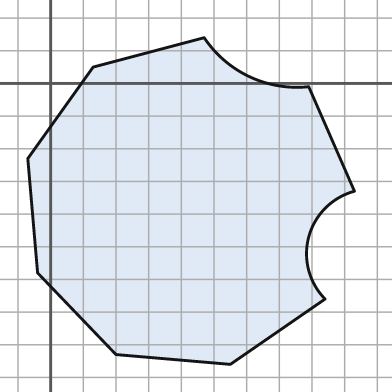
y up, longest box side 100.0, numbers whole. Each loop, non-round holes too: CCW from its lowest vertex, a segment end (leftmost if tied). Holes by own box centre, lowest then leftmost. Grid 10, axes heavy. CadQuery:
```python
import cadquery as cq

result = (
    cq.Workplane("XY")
    .moveTo(55.0, -86.0)
    .lineTo(84.0, -66.0)
    .threePointArc((79.0, -47.0), (93.0, -33.0))
    .lineTo(79.0, -1.0)
    .threePointArc((61.0, 2.0), (47.0, 14.0))
    .lineTo(13.0, 5.0)
    .lineTo(-7.0, -23.0)
    .lineTo(-4.0, -58.0)
    .lineTo(20.0, -83.0)
    .close()
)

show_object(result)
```